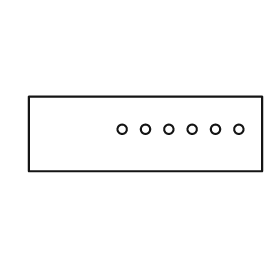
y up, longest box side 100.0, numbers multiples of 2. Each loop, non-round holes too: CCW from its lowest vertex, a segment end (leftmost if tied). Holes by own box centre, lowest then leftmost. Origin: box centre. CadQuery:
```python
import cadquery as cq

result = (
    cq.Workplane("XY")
    .moveTo(-50.0, -16.0)
    .lineTo(50.0, -16.0)
    .lineTo(50.0, 16.0)
    .lineTo(-50.0, 16.0)
    .close()
    .moveTo(-10.0, 2.0)
    .circle(2.0)
    .moveTo(0.0, 2.0)
    .circle(2.0)
    .moveTo(10.0, 2.0)
    .circle(2.0)
    .moveTo(20.0, 2.0)
    .circle(2.0)
    .moveTo(30.0, 2.0)
    .circle(2.0)
    .moveTo(40.0, 2.0)
    .circle(2.0)
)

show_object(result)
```